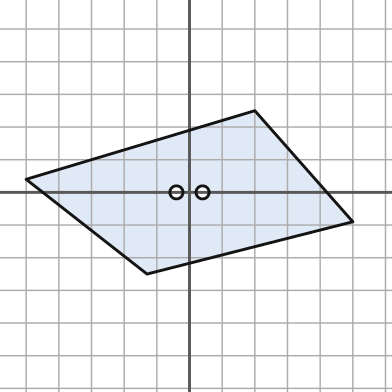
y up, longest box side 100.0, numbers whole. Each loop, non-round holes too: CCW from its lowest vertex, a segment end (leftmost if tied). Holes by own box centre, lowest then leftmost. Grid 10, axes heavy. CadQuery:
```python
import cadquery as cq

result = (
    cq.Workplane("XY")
    .moveTo(-13.0, -25.0)
    .lineTo(50.0, -9.0)
    .lineTo(20.0, 25.0)
    .lineTo(-50.0, 4.0)
    .close()
    .moveTo(-4.0, 0.0)
    .circle(2.0)
    .moveTo(4.0, 0.0)
    .circle(2.0)
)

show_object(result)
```